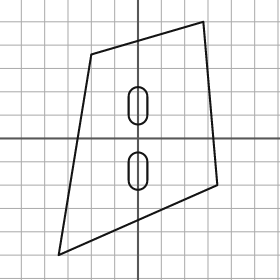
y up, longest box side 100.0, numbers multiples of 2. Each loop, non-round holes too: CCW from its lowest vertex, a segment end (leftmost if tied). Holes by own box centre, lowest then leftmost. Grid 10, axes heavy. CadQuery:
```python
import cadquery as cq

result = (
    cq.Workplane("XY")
    .moveTo(-34.0, -50.0)
    .lineTo(34.0, -20.0)
    .lineTo(28.0, 50.0)
    .lineTo(-20.0, 36.0)
    .close()
    .moveTo(-4.0, -18.0)
    .threePointArc((0.0, -22.0), (4.0, -18.0))
    .lineTo(4.0, -10.0)
    .threePointArc((0.0, -6.0), (-4.0, -10.0))
    .close()
    .moveTo(-4.0, 10.0)
    .threePointArc((0.0, 6.0), (4.0, 10.0))
    .lineTo(4.0, 18.0)
    .threePointArc((0.0, 22.0), (-4.0, 18.0))
    .close()
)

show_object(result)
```